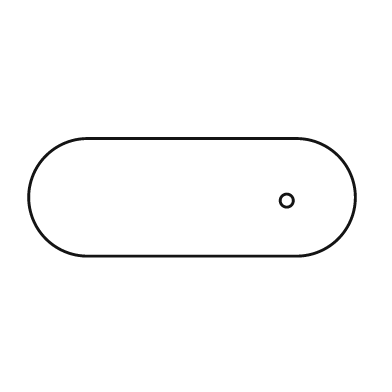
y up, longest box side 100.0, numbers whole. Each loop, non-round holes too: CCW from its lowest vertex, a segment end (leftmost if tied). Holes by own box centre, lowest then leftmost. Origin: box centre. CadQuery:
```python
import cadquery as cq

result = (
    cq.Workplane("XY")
    .moveTo(-32.0, -18.0)
    .lineTo(32.0, -18.0)
    .threePointArc((50.0, 0.0), (32.0, 18.0))
    .lineTo(-32.0, 18.0)
    .threePointArc((-50.0, 0.0), (-32.0, -18.0))
    .close()
    .moveTo(29.0, -1.0)
    .circle(2.0)
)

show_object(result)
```